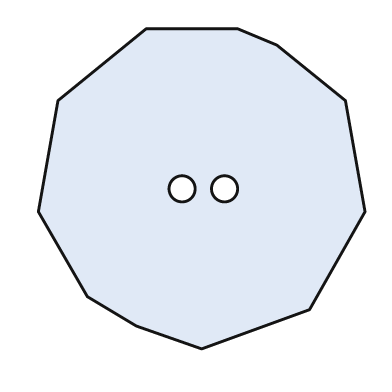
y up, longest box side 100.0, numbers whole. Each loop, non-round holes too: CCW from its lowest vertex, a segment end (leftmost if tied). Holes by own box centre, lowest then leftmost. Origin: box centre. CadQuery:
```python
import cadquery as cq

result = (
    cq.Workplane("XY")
    .moveTo(0.0, -49.0)
    .lineTo(33.0, -37.0)
    .lineTo(50.0, -7.0)
    .lineTo(44.0, 27.0)
    .lineTo(23.0, 44.0)
    .lineTo(11.0, 49.0)
    .lineTo(-17.0, 49.0)
    .lineTo(-44.0, 27.0)
    .lineTo(-50.0, -7.0)
    .lineTo(-35.0, -33.0)
    .lineTo(-20.0, -42.0)
    .close()
    .moveTo(-6.0, 0.0)
    .circle(4.0)
    .moveTo(7.0, 0.0)
    .circle(4.0)
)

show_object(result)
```